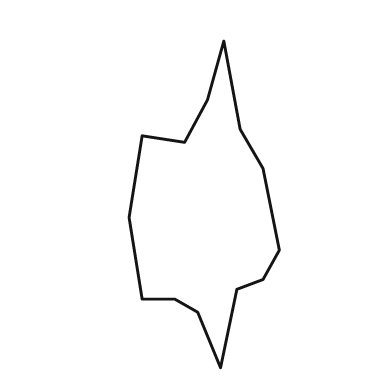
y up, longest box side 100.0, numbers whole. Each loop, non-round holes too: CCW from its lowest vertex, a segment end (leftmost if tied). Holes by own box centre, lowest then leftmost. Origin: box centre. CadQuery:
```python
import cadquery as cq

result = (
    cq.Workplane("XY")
    .moveTo(5.0, -50.0)
    .lineTo(10.0, -26.0)
    .lineTo(18.0, -23.0)
    .lineTo(23.0, -14.0)
    .lineTo(18.0, 11.0)
    .lineTo(11.0, 23.0)
    .lineTo(6.0, 50.0)
    .lineTo(1.0, 32.0)
    .lineTo(-6.0, 19.0)
    .lineTo(-19.0, 21.0)
    .lineTo(-23.0, -4.0)
    .lineTo(-19.0, -29.0)
    .lineTo(-9.0, -29.0)
    .lineTo(-2.0, -33.0)
    .close()
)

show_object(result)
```